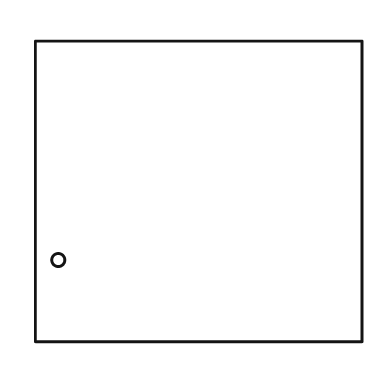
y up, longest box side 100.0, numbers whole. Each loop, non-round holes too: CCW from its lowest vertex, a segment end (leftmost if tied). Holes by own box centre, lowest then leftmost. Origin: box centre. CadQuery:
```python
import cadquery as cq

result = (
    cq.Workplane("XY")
    .moveTo(-50.0, -46.0)
    .lineTo(50.0, -46.0)
    .lineTo(50.0, 46.0)
    .lineTo(-50.0, 46.0)
    .close()
    .moveTo(-43.0, -21.0)
    .circle(2.0)
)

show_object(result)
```